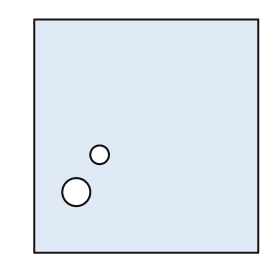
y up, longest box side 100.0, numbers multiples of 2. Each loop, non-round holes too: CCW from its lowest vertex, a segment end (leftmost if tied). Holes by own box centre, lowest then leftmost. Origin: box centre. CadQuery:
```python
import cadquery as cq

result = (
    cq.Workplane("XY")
    .moveTo(-48.0, -50.0)
    .lineTo(48.0, -50.0)
    .lineTo(48.0, 50.0)
    .lineTo(-48.0, 50.0)
    .close()
    .moveTo(-30.0, -24.0)
    .circle(6.0)
    .moveTo(-20.0, -8.0)
    .circle(4.0)
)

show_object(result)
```